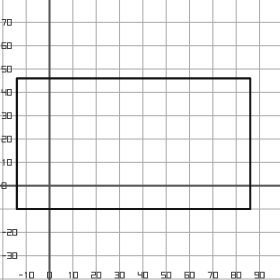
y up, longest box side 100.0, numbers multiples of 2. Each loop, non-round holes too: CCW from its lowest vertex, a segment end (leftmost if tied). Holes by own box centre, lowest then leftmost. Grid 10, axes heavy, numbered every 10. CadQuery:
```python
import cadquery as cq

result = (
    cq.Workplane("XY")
    .moveTo(-14.0, -10.0)
    .lineTo(86.0, -10.0)
    .lineTo(86.0, 46.0)
    .lineTo(-14.0, 46.0)
    .close()
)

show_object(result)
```